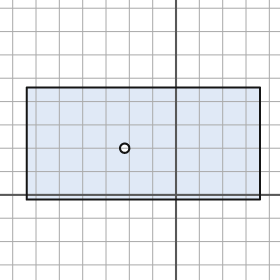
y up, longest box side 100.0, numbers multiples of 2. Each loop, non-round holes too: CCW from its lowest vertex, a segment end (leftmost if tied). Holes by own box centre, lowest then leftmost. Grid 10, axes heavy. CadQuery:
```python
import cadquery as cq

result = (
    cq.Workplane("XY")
    .moveTo(-64.0, -2.0)
    .lineTo(36.0, -2.0)
    .lineTo(36.0, 46.0)
    .lineTo(-64.0, 46.0)
    .close()
    .moveTo(-22.0, 20.0)
    .circle(2.0)
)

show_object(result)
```